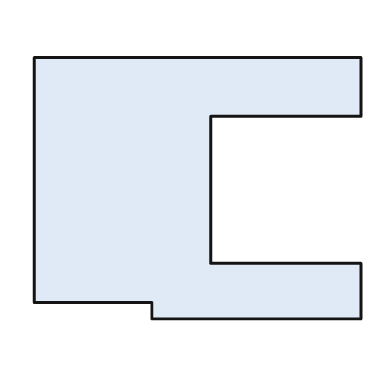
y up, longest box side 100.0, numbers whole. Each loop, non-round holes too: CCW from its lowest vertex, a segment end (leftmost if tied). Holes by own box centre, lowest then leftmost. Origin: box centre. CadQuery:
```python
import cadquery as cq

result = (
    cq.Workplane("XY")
    .moveTo(-14.0, -40.0)
    .lineTo(50.0, -40.0)
    .lineTo(50.0, -23.0)
    .lineTo(4.0, -23.0)
    .lineTo(4.0, 22.0)
    .lineTo(50.0, 22.0)
    .lineTo(50.0, 40.0)
    .lineTo(-50.0, 40.0)
    .lineTo(-50.0, -35.0)
    .lineTo(-14.0, -35.0)
    .close()
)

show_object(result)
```